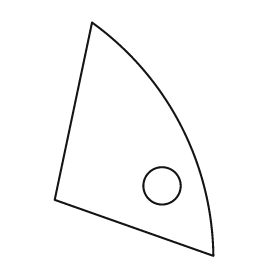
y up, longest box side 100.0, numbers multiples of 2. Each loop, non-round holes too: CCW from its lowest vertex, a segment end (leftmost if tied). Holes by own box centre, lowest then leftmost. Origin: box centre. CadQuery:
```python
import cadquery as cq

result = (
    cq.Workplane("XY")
    .moveTo(34.0, -50.0)
    .threePointArc((20.0, 6.0), (-18.0, 50.0))
    .lineTo(-34.0, -26.0)
    .close()
    .moveTo(12.0, -20.0)
    .circle(8.0)
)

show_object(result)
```